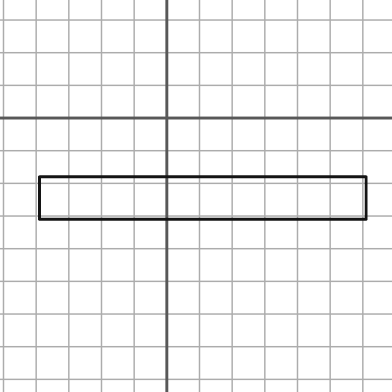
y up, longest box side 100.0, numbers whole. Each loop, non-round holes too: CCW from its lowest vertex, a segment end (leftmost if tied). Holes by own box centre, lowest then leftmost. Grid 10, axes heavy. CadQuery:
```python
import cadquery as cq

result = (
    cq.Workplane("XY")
    .moveTo(-39.0, -31.0)
    .lineTo(61.0, -31.0)
    .lineTo(61.0, -18.0)
    .lineTo(-39.0, -18.0)
    .close()
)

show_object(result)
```